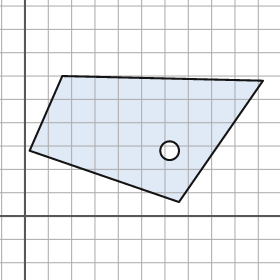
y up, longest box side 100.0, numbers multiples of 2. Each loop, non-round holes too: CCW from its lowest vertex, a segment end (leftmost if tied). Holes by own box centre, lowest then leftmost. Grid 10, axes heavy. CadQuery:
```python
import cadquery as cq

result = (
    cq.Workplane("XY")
    .moveTo(66.0, 6.0)
    .lineTo(102.0, 58.0)
    .lineTo(16.0, 60.0)
    .lineTo(2.0, 28.0)
    .close()
    .moveTo(62.0, 28.0)
    .circle(4.0)
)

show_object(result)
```